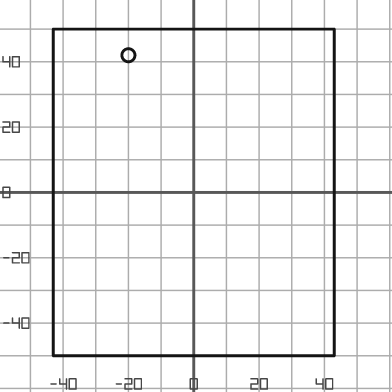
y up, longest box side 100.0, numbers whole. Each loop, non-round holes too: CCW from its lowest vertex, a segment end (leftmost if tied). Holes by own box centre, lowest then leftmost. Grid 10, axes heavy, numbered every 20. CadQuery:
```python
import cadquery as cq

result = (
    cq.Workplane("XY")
    .moveTo(-43.0, -50.0)
    .lineTo(43.0, -50.0)
    .lineTo(43.0, 50.0)
    .lineTo(-43.0, 50.0)
    .close()
    .moveTo(-20.0, 42.0)
    .circle(2.0)
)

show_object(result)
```